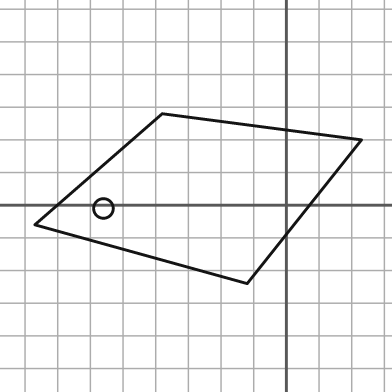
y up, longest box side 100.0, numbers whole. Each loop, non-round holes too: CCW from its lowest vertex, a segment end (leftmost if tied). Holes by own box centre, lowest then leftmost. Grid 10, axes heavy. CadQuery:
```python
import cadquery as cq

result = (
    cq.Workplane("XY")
    .moveTo(-12.0, -24.0)
    .lineTo(23.0, 20.0)
    .lineTo(-38.0, 28.0)
    .lineTo(-77.0, -6.0)
    .close()
    .moveTo(-56.0, -1.0)
    .circle(3.0)
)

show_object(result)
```